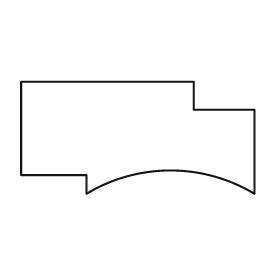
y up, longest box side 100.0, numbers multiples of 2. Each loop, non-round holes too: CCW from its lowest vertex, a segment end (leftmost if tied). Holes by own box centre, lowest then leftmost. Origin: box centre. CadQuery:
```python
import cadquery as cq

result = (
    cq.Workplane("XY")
    .moveTo(-22.0, -24.0)
    .threePointArc((14.0, -14.0), (50.0, -24.0))
    .lineTo(50.0, 12.0)
    .lineTo(24.0, 12.0)
    .lineTo(24.0, 24.0)
    .lineTo(-50.0, 24.0)
    .lineTo(-50.0, -16.0)
    .lineTo(-22.0, -16.0)
    .close()
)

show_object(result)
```